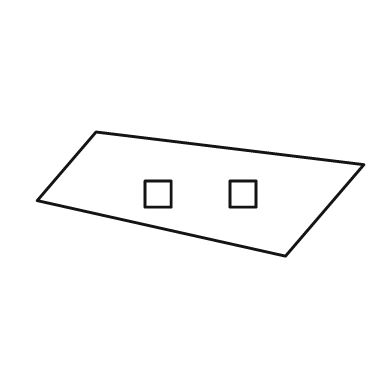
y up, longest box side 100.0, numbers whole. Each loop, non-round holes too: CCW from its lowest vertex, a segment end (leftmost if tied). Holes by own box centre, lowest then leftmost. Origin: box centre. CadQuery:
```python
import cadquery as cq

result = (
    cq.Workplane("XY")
    .moveTo(26.0, -19.0)
    .lineTo(50.0, 9.0)
    .lineTo(-32.0, 19.0)
    .lineTo(-50.0, -2.0)
    .close()
    .moveTo(-17.0, -4.0)
    .lineTo(-9.0, -4.0)
    .lineTo(-9.0, 4.0)
    .lineTo(-17.0, 4.0)
    .close()
    .moveTo(9.0, -4.0)
    .lineTo(17.0, -4.0)
    .lineTo(17.0, 4.0)
    .lineTo(9.0, 4.0)
    .close()
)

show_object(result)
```